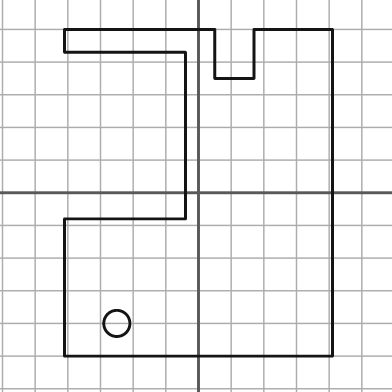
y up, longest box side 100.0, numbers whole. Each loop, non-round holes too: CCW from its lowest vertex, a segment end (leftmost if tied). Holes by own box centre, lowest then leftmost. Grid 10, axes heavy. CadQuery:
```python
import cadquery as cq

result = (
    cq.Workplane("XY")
    .moveTo(-41.0, -50.0)
    .lineTo(41.0, -50.0)
    .lineTo(41.0, 50.0)
    .lineTo(17.0, 50.0)
    .lineTo(17.0, 35.0)
    .lineTo(5.0, 35.0)
    .lineTo(5.0, 50.0)
    .lineTo(-41.0, 50.0)
    .lineTo(-41.0, 43.0)
    .lineTo(-4.0, 43.0)
    .lineTo(-4.0, -8.0)
    .lineTo(-41.0, -8.0)
    .close()
    .moveTo(-25.0, -40.0)
    .circle(4.0)
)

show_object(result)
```